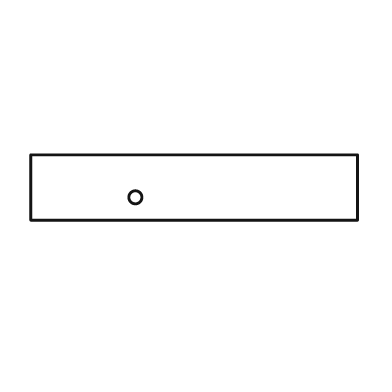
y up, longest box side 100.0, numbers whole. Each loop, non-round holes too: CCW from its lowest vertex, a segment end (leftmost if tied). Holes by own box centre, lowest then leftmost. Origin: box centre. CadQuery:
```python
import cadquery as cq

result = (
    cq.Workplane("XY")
    .moveTo(-50.0, -10.0)
    .lineTo(50.0, -10.0)
    .lineTo(50.0, 10.0)
    .lineTo(-50.0, 10.0)
    .close()
    .moveTo(-18.0, -3.0)
    .circle(2.0)
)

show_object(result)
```